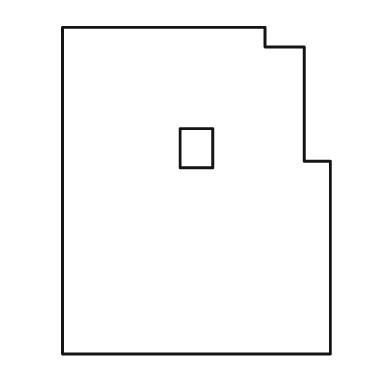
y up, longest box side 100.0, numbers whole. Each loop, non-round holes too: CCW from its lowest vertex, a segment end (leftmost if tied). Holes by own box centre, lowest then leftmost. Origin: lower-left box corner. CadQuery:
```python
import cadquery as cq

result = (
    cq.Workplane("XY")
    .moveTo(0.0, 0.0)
    .lineTo(82.0, 0.0)
    .lineTo(82.0, 59.0)
    .lineTo(74.0, 59.0)
    .lineTo(74.0, 94.0)
    .lineTo(62.0, 94.0)
    .lineTo(62.0, 100.0)
    .lineTo(0.0, 100.0)
    .close()
    .moveTo(36.0, 57.0)
    .lineTo(46.0, 57.0)
    .lineTo(46.0, 69.0)
    .lineTo(36.0, 69.0)
    .close()
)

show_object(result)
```